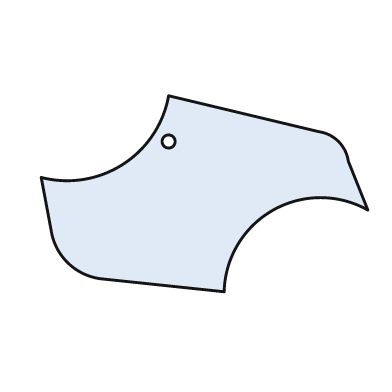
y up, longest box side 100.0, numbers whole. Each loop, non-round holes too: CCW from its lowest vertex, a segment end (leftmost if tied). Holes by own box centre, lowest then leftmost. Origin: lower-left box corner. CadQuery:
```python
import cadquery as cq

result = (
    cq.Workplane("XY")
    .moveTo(56.0, 0.0)
    .threePointArc((71.0, 25.0), (100.0, 25.0))
    .lineTo(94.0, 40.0)
    .threePointArc((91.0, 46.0), (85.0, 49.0))
    .lineTo(39.0, 60.0)
    .threePointArc((25.0, 39.0), (0.0, 35.0))
    .lineTo(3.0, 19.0)
    .threePointArc((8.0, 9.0), (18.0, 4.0))
    .close()
    .moveTo(39.0, 46.0)
    .circle(2.0)
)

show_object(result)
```